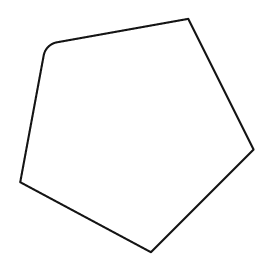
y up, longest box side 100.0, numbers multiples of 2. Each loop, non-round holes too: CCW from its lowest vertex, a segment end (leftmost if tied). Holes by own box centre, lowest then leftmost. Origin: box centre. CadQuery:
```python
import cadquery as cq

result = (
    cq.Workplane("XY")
    .moveTo(6.0, -50.0)
    .lineTo(50.0, -6.0)
    .lineTo(22.0, 50.0)
    .lineTo(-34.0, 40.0)
    .threePointArc((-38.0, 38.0), (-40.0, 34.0))
    .lineTo(-50.0, -20.0)
    .close()
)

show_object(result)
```